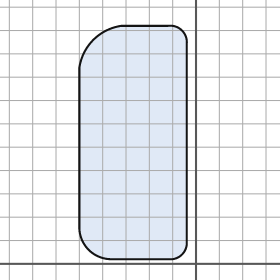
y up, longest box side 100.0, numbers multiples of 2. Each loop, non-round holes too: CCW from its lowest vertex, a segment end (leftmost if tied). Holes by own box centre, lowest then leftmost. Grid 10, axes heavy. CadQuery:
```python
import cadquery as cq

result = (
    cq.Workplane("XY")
    .moveTo(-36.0, 2.0)
    .lineTo(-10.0, 2.0)
    .threePointArc((-6.0, 4.0), (-4.0, 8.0))
    .lineTo(-4.0, 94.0)
    .threePointArc((-6.0, 100.0), (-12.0, 102.0))
    .lineTo(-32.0, 102.0)
    .threePointArc((-44.0, 96.0), (-50.0, 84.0))
    .lineTo(-50.0, 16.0)
    .threePointArc((-46.0, 6.0), (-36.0, 2.0))
    .close()
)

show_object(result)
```